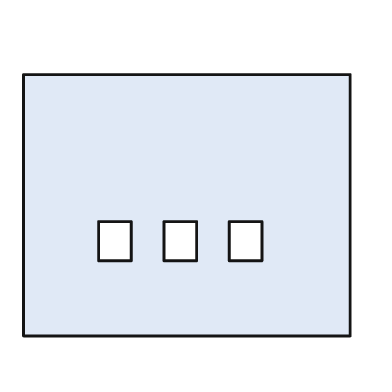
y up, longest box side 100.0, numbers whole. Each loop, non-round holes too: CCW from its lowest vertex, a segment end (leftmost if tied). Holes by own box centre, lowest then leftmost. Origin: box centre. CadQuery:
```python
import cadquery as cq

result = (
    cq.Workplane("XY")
    .moveTo(-50.0, -40.0)
    .lineTo(50.0, -40.0)
    .lineTo(50.0, 40.0)
    .lineTo(-50.0, 40.0)
    .close()
    .moveTo(-27.0, -17.0)
    .lineTo(-17.0, -17.0)
    .lineTo(-17.0, -5.0)
    .lineTo(-27.0, -5.0)
    .close()
    .moveTo(-7.0, -17.0)
    .lineTo(3.0, -17.0)
    .lineTo(3.0, -5.0)
    .lineTo(-7.0, -5.0)
    .close()
    .moveTo(13.0, -17.0)
    .lineTo(23.0, -17.0)
    .lineTo(23.0, -5.0)
    .lineTo(13.0, -5.0)
    .close()
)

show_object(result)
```